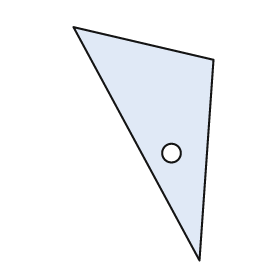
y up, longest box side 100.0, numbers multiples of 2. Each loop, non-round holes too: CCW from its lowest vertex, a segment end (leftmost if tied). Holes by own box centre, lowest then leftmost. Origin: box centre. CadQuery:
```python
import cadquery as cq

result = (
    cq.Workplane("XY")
    .moveTo(24.0, -50.0)
    .lineTo(30.0, 36.0)
    .lineTo(-30.0, 50.0)
    .close()
    .moveTo(12.0, -4.0)
    .circle(4.0)
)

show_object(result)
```